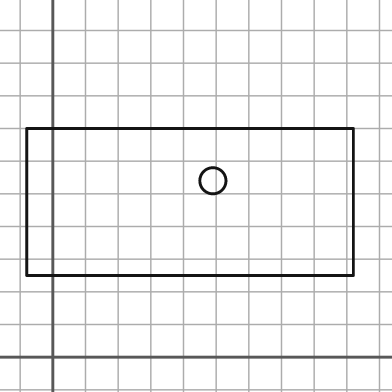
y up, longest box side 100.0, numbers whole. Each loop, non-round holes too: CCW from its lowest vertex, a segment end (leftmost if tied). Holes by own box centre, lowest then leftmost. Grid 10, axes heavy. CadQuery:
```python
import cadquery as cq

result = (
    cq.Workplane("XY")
    .moveTo(-8.0, 25.0)
    .lineTo(92.0, 25.0)
    .lineTo(92.0, 70.0)
    .lineTo(-8.0, 70.0)
    .close()
    .moveTo(49.0, 54.0)
    .circle(4.0)
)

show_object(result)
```